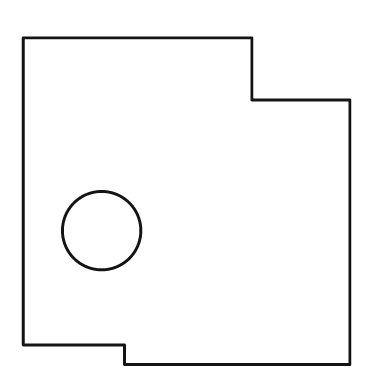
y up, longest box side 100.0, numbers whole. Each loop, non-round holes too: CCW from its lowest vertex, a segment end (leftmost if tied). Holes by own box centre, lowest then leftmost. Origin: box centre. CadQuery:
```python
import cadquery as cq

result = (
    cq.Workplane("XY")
    .moveTo(-19.0, -50.0)
    .lineTo(50.0, -50.0)
    .lineTo(50.0, 31.0)
    .lineTo(20.0, 31.0)
    .lineTo(20.0, 50.0)
    .lineTo(-50.0, 50.0)
    .lineTo(-50.0, -44.0)
    .lineTo(-19.0, -44.0)
    .close()
    .moveTo(-26.0, -9.0)
    .circle(12.0)
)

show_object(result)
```